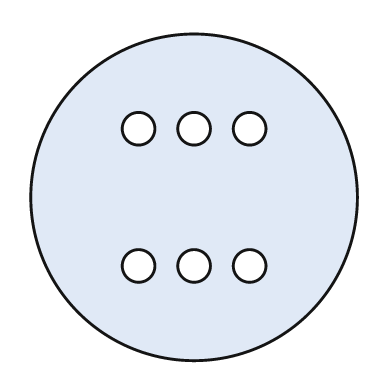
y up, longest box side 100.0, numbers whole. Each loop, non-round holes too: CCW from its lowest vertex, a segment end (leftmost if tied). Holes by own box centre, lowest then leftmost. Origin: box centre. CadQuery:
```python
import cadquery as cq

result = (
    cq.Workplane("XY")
    .moveTo(0.0, 0.0)
    .circle(50.0)
    .moveTo(-17.0, -21.0)
    .circle(5.0)
    .moveTo(0.0, -21.0)
    .circle(5.0)
    .moveTo(17.0, -21.0)
    .circle(5.0)
    .moveTo(-17.0, 21.0)
    .circle(5.0)
    .moveTo(0.0, 21.0)
    .circle(5.0)
    .moveTo(17.0, 21.0)
    .circle(5.0)
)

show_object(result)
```